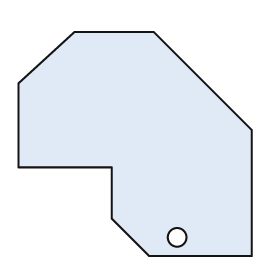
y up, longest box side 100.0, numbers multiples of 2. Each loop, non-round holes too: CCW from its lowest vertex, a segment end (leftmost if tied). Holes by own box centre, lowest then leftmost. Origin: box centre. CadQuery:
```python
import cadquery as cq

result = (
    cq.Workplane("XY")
    .moveTo(6.0, -48.0)
    .lineTo(50.0, -48.0)
    .lineTo(50.0, 6.0)
    .lineTo(8.0, 48.0)
    .lineTo(-26.0, 48.0)
    .lineTo(-50.0, 26.0)
    .lineTo(-50.0, -10.0)
    .lineTo(-10.0, -10.0)
    .lineTo(-10.0, -32.0)
    .close()
    .moveTo(18.0, -40.0)
    .circle(4.0)
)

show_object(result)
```